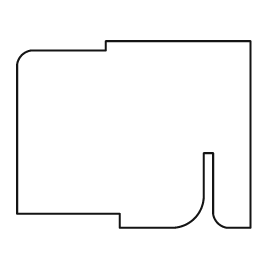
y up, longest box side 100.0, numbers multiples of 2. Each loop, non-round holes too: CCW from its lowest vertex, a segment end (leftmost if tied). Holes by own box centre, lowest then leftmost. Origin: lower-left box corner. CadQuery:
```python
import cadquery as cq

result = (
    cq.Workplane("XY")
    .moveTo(44.0, 0.0)
    .lineTo(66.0, 0.0)
    .threePointArc((76.0, 4.0), (80.0, 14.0))
    .lineTo(80.0, 32.0)
    .lineTo(84.0, 32.0)
    .lineTo(84.0, 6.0)
    .threePointArc((86.0, 2.0), (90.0, 0.0))
    .lineTo(100.0, 0.0)
    .lineTo(100.0, 80.0)
    .lineTo(38.0, 80.0)
    .lineTo(38.0, 76.0)
    .lineTo(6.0, 76.0)
    .threePointArc((2.0, 74.0), (0.0, 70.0))
    .lineTo(0.0, 6.0)
    .lineTo(44.0, 6.0)
    .close()
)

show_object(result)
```